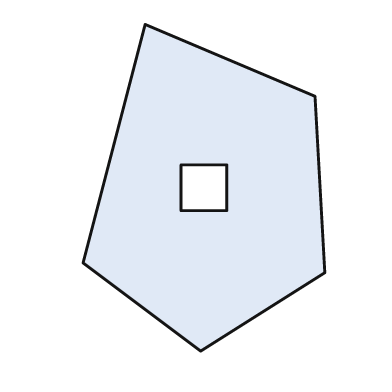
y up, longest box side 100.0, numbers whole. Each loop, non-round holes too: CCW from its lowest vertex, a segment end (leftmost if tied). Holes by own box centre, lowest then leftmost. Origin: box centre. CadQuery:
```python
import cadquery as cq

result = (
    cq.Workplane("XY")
    .moveTo(-1.0, -50.0)
    .lineTo(37.0, -26.0)
    .lineTo(34.0, 28.0)
    .lineTo(-18.0, 50.0)
    .lineTo(-37.0, -23.0)
    .close()
    .moveTo(-7.0, -7.0)
    .lineTo(7.0, -7.0)
    .lineTo(7.0, 7.0)
    .lineTo(-7.0, 7.0)
    .close()
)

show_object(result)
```